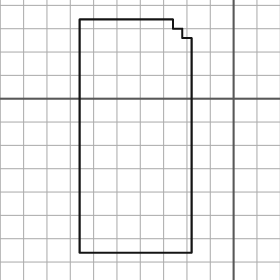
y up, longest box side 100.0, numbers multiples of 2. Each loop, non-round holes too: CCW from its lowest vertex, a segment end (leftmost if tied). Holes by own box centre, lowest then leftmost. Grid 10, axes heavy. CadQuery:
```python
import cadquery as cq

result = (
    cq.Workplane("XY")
    .moveTo(-66.0, -66.0)
    .lineTo(-18.0, -66.0)
    .lineTo(-18.0, 26.0)
    .lineTo(-22.0, 26.0)
    .lineTo(-22.0, 30.0)
    .lineTo(-26.0, 30.0)
    .lineTo(-26.0, 34.0)
    .lineTo(-66.0, 34.0)
    .close()
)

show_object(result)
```